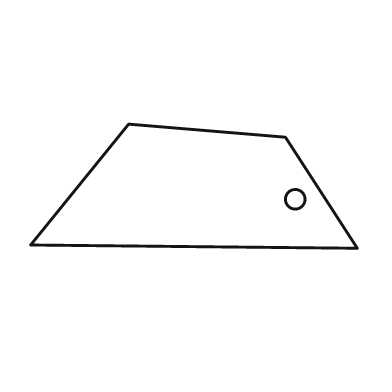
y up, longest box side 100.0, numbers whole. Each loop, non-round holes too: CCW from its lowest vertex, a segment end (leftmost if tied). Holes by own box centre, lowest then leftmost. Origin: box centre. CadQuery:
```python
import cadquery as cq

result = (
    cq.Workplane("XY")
    .moveTo(50.0, -19.0)
    .lineTo(28.0, 15.0)
    .lineTo(-20.0, 19.0)
    .lineTo(-50.0, -18.0)
    .close()
    .moveTo(31.0, -4.0)
    .circle(3.0)
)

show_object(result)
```